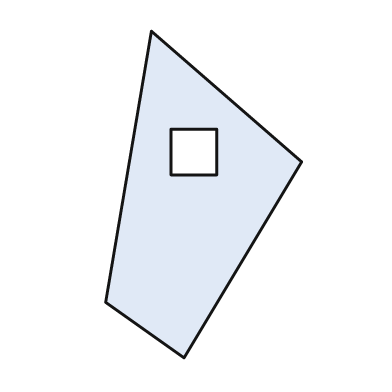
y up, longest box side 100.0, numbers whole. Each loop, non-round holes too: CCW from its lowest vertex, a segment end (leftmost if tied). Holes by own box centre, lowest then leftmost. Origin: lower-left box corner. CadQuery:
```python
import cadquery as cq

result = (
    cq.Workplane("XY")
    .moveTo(24.0, 0.0)
    .lineTo(60.0, 60.0)
    .lineTo(14.0, 100.0)
    .lineTo(0.0, 17.0)
    .close()
    .moveTo(20.0, 56.0)
    .lineTo(34.0, 56.0)
    .lineTo(34.0, 70.0)
    .lineTo(20.0, 70.0)
    .close()
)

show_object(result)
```